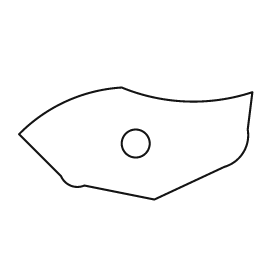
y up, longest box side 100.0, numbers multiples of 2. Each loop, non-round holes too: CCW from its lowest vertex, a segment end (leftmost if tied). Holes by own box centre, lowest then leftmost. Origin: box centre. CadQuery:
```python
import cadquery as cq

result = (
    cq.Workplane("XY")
    .moveTo(8.0, -24.0)
    .lineTo(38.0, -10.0)
    .threePointArc((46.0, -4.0), (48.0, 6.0))
    .lineTo(50.0, 22.0)
    .threePointArc((22.0, 18.0), (-6.0, 24.0))
    .threePointArc((-30.0, 18.0), (-50.0, 4.0))
    .lineTo(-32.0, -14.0)
    .threePointArc((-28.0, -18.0), (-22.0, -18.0))
    .close()
    .moveTo(0.0, 0.0)
    .circle(6.0)
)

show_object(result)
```